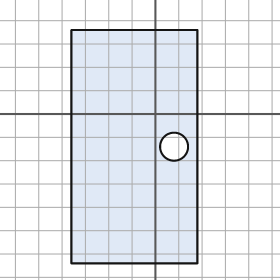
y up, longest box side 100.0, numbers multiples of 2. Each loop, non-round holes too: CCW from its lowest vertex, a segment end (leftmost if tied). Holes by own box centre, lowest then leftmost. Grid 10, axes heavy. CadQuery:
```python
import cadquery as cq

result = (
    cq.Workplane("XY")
    .moveTo(-36.0, -64.0)
    .lineTo(18.0, -64.0)
    .lineTo(18.0, 36.0)
    .lineTo(-36.0, 36.0)
    .close()
    .moveTo(8.0, -14.0)
    .circle(6.0)
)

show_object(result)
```